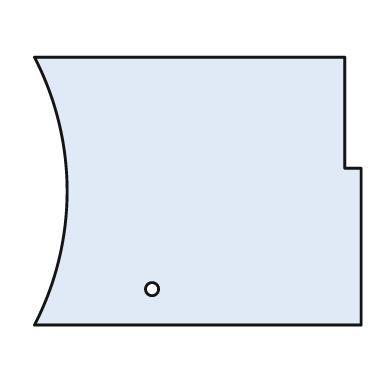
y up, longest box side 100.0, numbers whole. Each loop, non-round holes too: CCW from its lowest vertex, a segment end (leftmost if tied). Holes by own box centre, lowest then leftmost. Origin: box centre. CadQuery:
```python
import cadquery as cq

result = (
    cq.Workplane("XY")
    .moveTo(-50.0, -41.0)
    .lineTo(50.0, -41.0)
    .lineTo(50.0, 7.0)
    .lineTo(45.0, 7.0)
    .lineTo(45.0, 41.0)
    .lineTo(-50.0, 41.0)
    .threePointArc((-40.0, 0.0), (-50.0, -41.0))
    .close()
    .moveTo(-14.0, -30.0)
    .circle(2.0)
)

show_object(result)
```